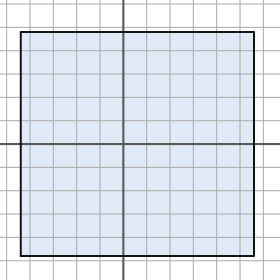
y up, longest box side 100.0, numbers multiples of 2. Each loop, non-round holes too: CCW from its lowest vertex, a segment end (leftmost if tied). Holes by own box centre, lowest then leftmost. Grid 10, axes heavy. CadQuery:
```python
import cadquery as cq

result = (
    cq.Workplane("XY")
    .moveTo(-44.0, -48.0)
    .lineTo(56.0, -48.0)
    .lineTo(56.0, 48.0)
    .lineTo(-44.0, 48.0)
    .close()
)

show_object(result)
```